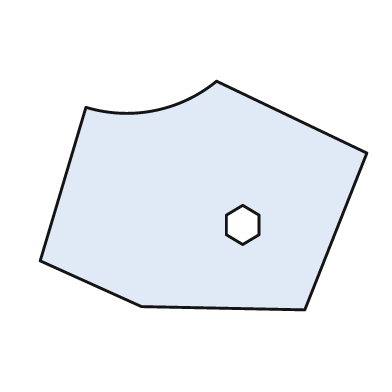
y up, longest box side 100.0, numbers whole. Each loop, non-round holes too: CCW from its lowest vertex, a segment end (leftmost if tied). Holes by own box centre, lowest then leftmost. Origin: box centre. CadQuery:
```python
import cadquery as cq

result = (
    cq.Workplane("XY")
    .moveTo(31.0, -35.0)
    .lineTo(50.0, 13.0)
    .lineTo(4.0, 35.0)
    .threePointArc((-15.0, 26.0), (-36.0, 27.0))
    .lineTo(-50.0, -20.0)
    .lineTo(-19.0, -34.0)
    .close()
    .moveTo(12.0, -15.0)
    .lineTo(17.0, -12.0)
    .lineTo(17.0, -6.0)
    .lineTo(12.0, -3.0)
    .lineTo(7.0, -6.0)
    .lineTo(7.0, -12.0)
    .close()
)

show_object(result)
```